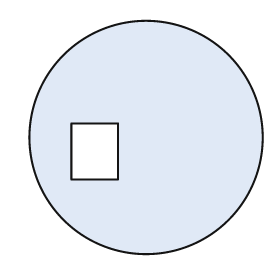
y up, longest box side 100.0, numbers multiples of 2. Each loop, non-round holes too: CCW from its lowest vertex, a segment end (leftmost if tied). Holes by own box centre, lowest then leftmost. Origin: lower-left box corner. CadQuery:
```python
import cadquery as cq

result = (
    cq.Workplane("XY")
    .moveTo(50.0, 50.0)
    .circle(50.0)
    .moveTo(18.0, 32.0)
    .lineTo(38.0, 32.0)
    .lineTo(38.0, 56.0)
    .lineTo(18.0, 56.0)
    .close()
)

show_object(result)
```